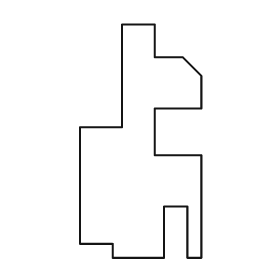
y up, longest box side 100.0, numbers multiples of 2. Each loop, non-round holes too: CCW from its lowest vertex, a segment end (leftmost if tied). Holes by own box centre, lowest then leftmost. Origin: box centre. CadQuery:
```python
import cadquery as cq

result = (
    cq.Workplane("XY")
    .moveTo(-12.0, -50.0)
    .lineTo(10.0, -50.0)
    .lineTo(10.0, -28.0)
    .lineTo(20.0, -28.0)
    .lineTo(20.0, -50.0)
    .lineTo(26.0, -50.0)
    .lineTo(26.0, -6.0)
    .lineTo(6.0, -6.0)
    .lineTo(6.0, 14.0)
    .lineTo(26.0, 14.0)
    .lineTo(26.0, 28.0)
    .lineTo(18.0, 36.0)
    .lineTo(6.0, 36.0)
    .lineTo(6.0, 50.0)
    .lineTo(-8.0, 50.0)
    .lineTo(-8.0, 6.0)
    .lineTo(-26.0, 6.0)
    .lineTo(-26.0, -44.0)
    .lineTo(-12.0, -44.0)
    .close()
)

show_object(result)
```